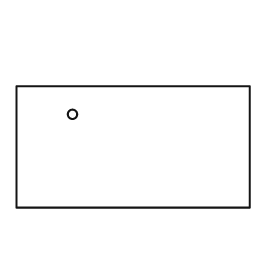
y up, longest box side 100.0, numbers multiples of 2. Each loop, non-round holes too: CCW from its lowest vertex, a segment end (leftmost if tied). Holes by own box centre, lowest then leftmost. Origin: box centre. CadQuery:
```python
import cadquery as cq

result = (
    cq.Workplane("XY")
    .moveTo(-50.0, -26.0)
    .lineTo(50.0, -26.0)
    .lineTo(50.0, 26.0)
    .lineTo(-50.0, 26.0)
    .close()
    .moveTo(-26.0, 14.0)
    .circle(2.0)
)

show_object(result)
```